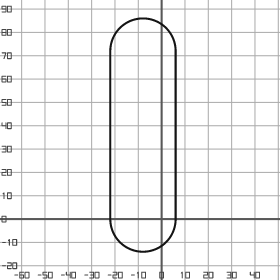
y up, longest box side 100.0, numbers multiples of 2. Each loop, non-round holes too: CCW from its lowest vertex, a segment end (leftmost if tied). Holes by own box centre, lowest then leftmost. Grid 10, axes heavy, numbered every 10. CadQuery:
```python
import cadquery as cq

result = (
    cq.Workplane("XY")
    .moveTo(-22.0, 0.0)
    .threePointArc((-8.0, -14.0), (6.0, 0.0))
    .lineTo(6.0, 72.0)
    .threePointArc((-8.0, 86.0), (-22.0, 72.0))
    .close()
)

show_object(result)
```